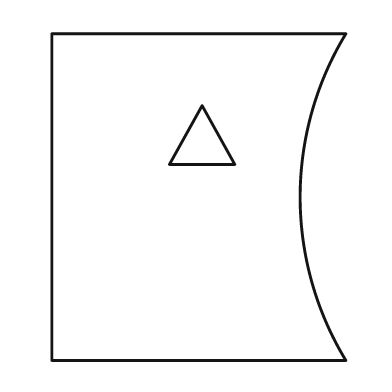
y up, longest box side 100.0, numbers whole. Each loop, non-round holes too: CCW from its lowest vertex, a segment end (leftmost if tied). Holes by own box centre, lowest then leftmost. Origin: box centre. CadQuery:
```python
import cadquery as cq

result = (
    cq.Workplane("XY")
    .moveTo(-45.0, -50.0)
    .lineTo(45.0, -50.0)
    .threePointArc((31.0, 0.0), (45.0, 50.0))
    .lineTo(-45.0, 50.0)
    .close()
    .moveTo(-9.0, 10.0)
    .lineTo(11.0, 10.0)
    .lineTo(1.0, 28.0)
    .close()
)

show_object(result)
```